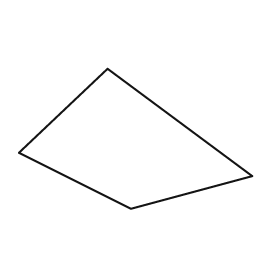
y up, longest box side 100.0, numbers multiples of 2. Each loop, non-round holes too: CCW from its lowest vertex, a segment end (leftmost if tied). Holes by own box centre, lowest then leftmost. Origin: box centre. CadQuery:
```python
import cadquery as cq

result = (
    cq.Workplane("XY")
    .moveTo(-2.0, -30.0)
    .lineTo(50.0, -16.0)
    .lineTo(-12.0, 30.0)
    .lineTo(-50.0, -6.0)
    .close()
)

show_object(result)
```